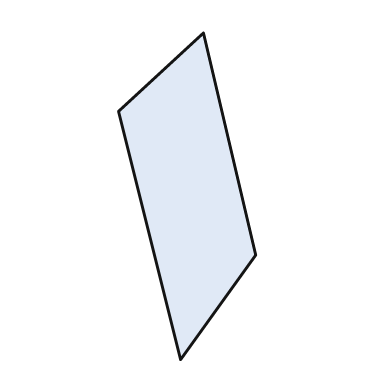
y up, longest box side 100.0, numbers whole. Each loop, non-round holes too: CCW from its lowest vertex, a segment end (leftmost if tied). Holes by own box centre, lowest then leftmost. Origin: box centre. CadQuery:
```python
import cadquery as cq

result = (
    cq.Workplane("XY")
    .moveTo(-2.0, -50.0)
    .lineTo(21.0, -18.0)
    .lineTo(5.0, 50.0)
    .lineTo(-21.0, 26.0)
    .close()
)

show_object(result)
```